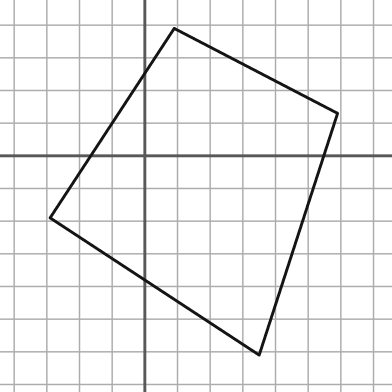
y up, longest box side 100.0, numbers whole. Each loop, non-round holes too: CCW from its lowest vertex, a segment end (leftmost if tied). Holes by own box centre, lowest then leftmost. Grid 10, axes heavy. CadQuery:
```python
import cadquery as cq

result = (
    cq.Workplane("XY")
    .moveTo(35.0, -61.0)
    .lineTo(59.0, 13.0)
    .lineTo(9.0, 39.0)
    .lineTo(-29.0, -19.0)
    .close()
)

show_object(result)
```